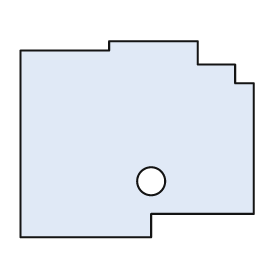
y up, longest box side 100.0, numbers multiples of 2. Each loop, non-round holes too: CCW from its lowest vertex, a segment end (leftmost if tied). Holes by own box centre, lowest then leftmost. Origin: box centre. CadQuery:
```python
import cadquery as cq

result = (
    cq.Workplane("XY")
    .moveTo(-50.0, -42.0)
    .lineTo(6.0, -42.0)
    .lineTo(6.0, -32.0)
    .lineTo(50.0, -32.0)
    .lineTo(50.0, 24.0)
    .lineTo(42.0, 24.0)
    .lineTo(42.0, 32.0)
    .lineTo(26.0, 32.0)
    .lineTo(26.0, 42.0)
    .lineTo(-12.0, 42.0)
    .lineTo(-12.0, 38.0)
    .lineTo(-50.0, 38.0)
    .close()
    .moveTo(6.0, -18.0)
    .circle(6.0)
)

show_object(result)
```